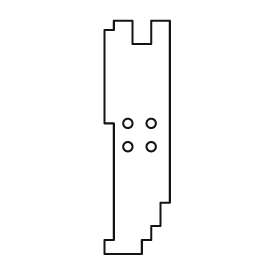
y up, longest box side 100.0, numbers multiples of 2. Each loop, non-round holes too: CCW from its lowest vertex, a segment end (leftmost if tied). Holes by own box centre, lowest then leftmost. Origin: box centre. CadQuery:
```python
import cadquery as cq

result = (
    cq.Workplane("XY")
    .moveTo(-14.0, -50.0)
    .lineTo(2.0, -50.0)
    .lineTo(2.0, -44.0)
    .lineTo(6.0, -44.0)
    .lineTo(6.0, -38.0)
    .lineTo(10.0, -38.0)
    .lineTo(10.0, -28.0)
    .lineTo(14.0, -28.0)
    .lineTo(14.0, 50.0)
    .lineTo(6.0, 50.0)
    .lineTo(6.0, 40.0)
    .lineTo(-2.0, 40.0)
    .lineTo(-2.0, 50.0)
    .lineTo(-10.0, 50.0)
    .lineTo(-10.0, 46.0)
    .lineTo(-14.0, 46.0)
    .lineTo(-14.0, 6.0)
    .lineTo(-10.0, 6.0)
    .lineTo(-10.0, -44.0)
    .lineTo(-14.0, -44.0)
    .close()
    .moveTo(-4.0, -4.0)
    .circle(2.0)
    .moveTo(6.0, -4.0)
    .circle(2.0)
    .moveTo(-4.0, 6.0)
    .circle(2.0)
    .moveTo(6.0, 6.0)
    .circle(2.0)
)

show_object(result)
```